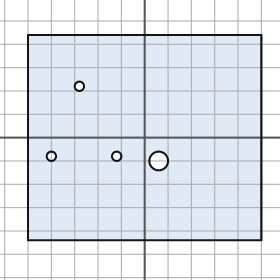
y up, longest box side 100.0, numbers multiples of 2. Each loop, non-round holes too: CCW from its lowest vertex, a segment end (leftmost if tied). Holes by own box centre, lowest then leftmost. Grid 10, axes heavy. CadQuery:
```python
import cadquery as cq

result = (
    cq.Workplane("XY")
    .moveTo(-50.0, -44.0)
    .lineTo(50.0, -44.0)
    .lineTo(50.0, 44.0)
    .lineTo(-50.0, 44.0)
    .close()
    .moveTo(6.0, -10.0)
    .circle(4.0)
    .moveTo(-40.0, -8.0)
    .circle(2.0)
    .moveTo(-12.0, -8.0)
    .circle(2.0)
    .moveTo(-28.0, 22.0)
    .circle(2.0)
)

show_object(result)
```